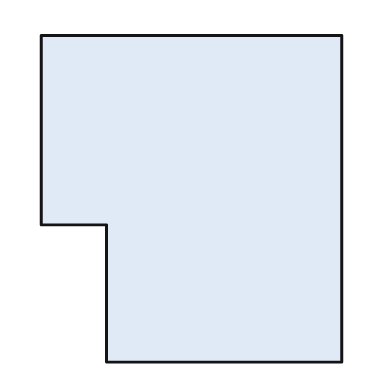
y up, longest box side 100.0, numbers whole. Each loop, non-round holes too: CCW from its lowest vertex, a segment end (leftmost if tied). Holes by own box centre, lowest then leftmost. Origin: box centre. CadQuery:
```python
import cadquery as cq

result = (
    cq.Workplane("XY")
    .moveTo(-26.0, -50.0)
    .lineTo(46.0, -50.0)
    .lineTo(46.0, 50.0)
    .lineTo(-46.0, 50.0)
    .lineTo(-46.0, -8.0)
    .lineTo(-26.0, -8.0)
    .close()
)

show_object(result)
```